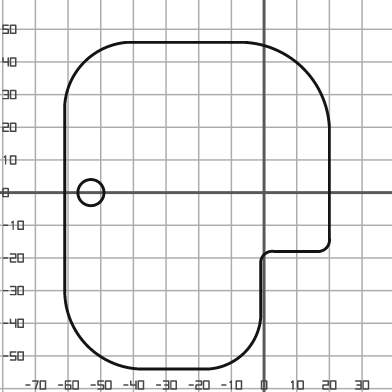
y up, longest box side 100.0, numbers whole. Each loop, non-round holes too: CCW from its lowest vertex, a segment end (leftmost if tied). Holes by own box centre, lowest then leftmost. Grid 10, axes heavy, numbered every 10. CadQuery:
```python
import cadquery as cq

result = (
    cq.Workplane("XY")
    .moveTo(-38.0, -54.0)
    .lineTo(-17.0, -54.0)
    .threePointArc((-6.0, -49.0), (-1.0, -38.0))
    .lineTo(-1.0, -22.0)
    .threePointArc((0.0, -19.0), (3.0, -18.0))
    .lineTo(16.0, -18.0)
    .threePointArc((19.0, -17.0), (20.0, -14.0))
    .lineTo(20.0, 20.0)
    .threePointArc((12.0, 38.0), (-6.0, 46.0))
    .lineTo(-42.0, 46.0)
    .threePointArc((-55.0, 40.0), (-61.0, 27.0))
    .lineTo(-61.0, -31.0)
    .threePointArc((-54.0, -47.0), (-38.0, -54.0))
    .close()
    .moveTo(-53.0, 0.0)
    .circle(4.0)
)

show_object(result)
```